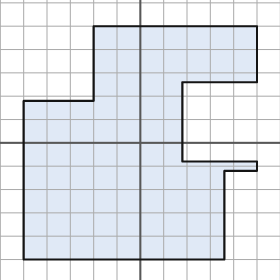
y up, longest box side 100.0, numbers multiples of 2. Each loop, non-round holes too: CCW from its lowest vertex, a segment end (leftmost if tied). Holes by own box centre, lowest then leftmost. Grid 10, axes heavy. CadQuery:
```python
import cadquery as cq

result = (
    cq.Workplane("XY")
    .moveTo(-50.0, -50.0)
    .lineTo(36.0, -50.0)
    .lineTo(36.0, -12.0)
    .lineTo(50.0, -12.0)
    .lineTo(50.0, -8.0)
    .lineTo(18.0, -8.0)
    .lineTo(18.0, 26.0)
    .lineTo(50.0, 26.0)
    .lineTo(50.0, 50.0)
    .lineTo(-20.0, 50.0)
    .lineTo(-20.0, 18.0)
    .lineTo(-50.0, 18.0)
    .close()
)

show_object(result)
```